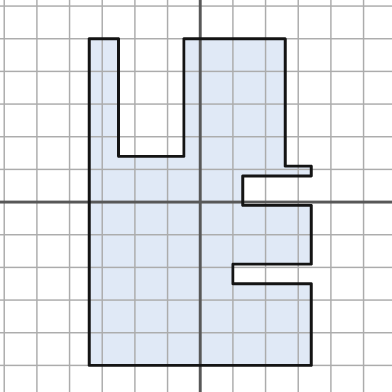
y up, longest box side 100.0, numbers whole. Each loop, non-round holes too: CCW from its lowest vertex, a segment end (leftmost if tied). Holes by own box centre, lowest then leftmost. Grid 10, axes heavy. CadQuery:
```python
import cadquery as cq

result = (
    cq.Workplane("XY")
    .moveTo(-34.0, -50.0)
    .lineTo(34.0, -50.0)
    .lineTo(34.0, -25.0)
    .lineTo(10.0, -25.0)
    .lineTo(10.0, -19.0)
    .lineTo(34.0, -19.0)
    .lineTo(34.0, -1.0)
    .lineTo(13.0, -1.0)
    .lineTo(13.0, 8.0)
    .lineTo(34.0, 8.0)
    .lineTo(34.0, 11.0)
    .lineTo(26.0, 11.0)
    .lineTo(26.0, 50.0)
    .lineTo(-5.0, 50.0)
    .lineTo(-5.0, 14.0)
    .lineTo(-25.0, 14.0)
    .lineTo(-25.0, 50.0)
    .lineTo(-34.0, 50.0)
    .close()
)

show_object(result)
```